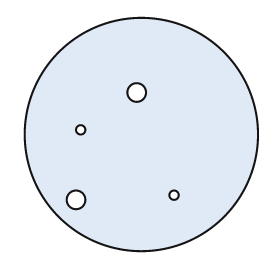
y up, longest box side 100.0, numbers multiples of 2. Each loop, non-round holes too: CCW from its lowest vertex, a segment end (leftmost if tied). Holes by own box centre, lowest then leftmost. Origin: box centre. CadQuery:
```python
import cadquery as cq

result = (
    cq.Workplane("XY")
    .moveTo(0.0, 0.0)
    .circle(50.0)
    .moveTo(-28.0, -28.0)
    .circle(4.0)
    .moveTo(14.0, -26.0)
    .circle(2.0)
    .moveTo(-26.0, 2.0)
    .circle(2.0)
    .moveTo(-2.0, 18.0)
    .circle(4.0)
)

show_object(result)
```